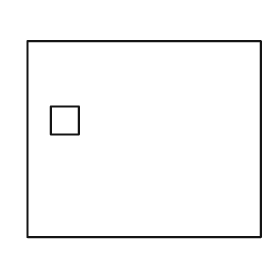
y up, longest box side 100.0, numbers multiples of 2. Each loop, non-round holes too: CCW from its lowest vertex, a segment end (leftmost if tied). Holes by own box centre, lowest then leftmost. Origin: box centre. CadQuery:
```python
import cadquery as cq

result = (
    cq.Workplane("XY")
    .moveTo(-50.0, -42.0)
    .lineTo(50.0, -42.0)
    .lineTo(50.0, 42.0)
    .lineTo(-50.0, 42.0)
    .close()
    .moveTo(-40.0, 2.0)
    .lineTo(-28.0, 2.0)
    .lineTo(-28.0, 14.0)
    .lineTo(-40.0, 14.0)
    .close()
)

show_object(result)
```